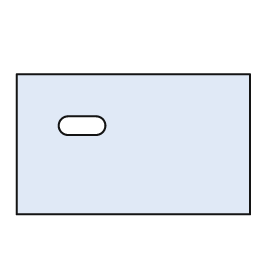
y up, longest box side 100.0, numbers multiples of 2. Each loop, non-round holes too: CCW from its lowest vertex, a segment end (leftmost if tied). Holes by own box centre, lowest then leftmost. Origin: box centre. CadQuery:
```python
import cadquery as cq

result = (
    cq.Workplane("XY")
    .moveTo(-50.0, -30.0)
    .lineTo(50.0, -30.0)
    .lineTo(50.0, 30.0)
    .lineTo(-50.0, 30.0)
    .close()
    .moveTo(-28.0, 4.0)
    .lineTo(-16.0, 4.0)
    .threePointArc((-12.0, 8.0), (-16.0, 12.0))
    .lineTo(-28.0, 12.0)
    .threePointArc((-32.0, 8.0), (-28.0, 4.0))
    .close()
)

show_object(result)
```